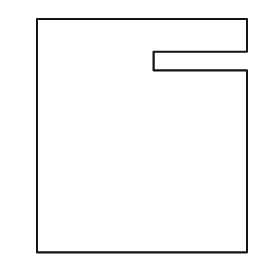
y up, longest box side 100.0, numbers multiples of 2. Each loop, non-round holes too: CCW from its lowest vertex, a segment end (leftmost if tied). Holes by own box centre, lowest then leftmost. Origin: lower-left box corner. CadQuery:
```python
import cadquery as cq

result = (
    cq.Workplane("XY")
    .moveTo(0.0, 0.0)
    .lineTo(90.0, 0.0)
    .lineTo(90.0, 78.0)
    .lineTo(50.0, 78.0)
    .lineTo(50.0, 86.0)
    .lineTo(90.0, 86.0)
    .lineTo(90.0, 100.0)
    .lineTo(0.0, 100.0)
    .close()
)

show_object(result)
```